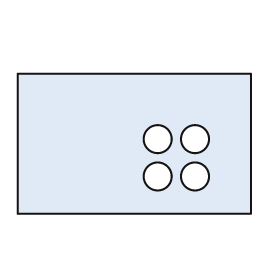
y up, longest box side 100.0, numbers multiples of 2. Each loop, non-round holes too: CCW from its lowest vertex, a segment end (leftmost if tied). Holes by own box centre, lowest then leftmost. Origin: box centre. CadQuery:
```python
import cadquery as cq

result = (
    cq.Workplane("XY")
    .moveTo(-50.0, -30.0)
    .lineTo(50.0, -30.0)
    .lineTo(50.0, 30.0)
    .lineTo(-50.0, 30.0)
    .close()
    .moveTo(10.0, -14.0)
    .circle(6.0)
    .moveTo(26.0, -14.0)
    .circle(6.0)
    .moveTo(10.0, 2.0)
    .circle(6.0)
    .moveTo(26.0, 2.0)
    .circle(6.0)
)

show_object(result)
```